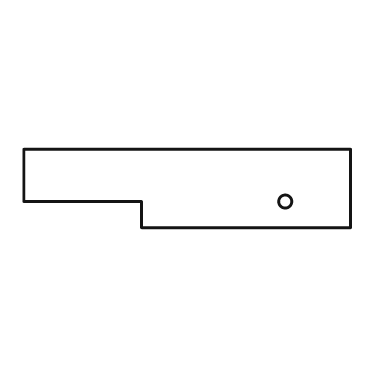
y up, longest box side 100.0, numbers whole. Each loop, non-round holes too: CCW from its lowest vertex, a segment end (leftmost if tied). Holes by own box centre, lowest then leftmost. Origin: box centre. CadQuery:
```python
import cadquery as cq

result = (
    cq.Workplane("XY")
    .moveTo(-14.0, -12.0)
    .lineTo(50.0, -12.0)
    .lineTo(50.0, 12.0)
    .lineTo(-50.0, 12.0)
    .lineTo(-50.0, -4.0)
    .lineTo(-14.0, -4.0)
    .close()
    .moveTo(30.0, -4.0)
    .circle(2.0)
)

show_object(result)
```